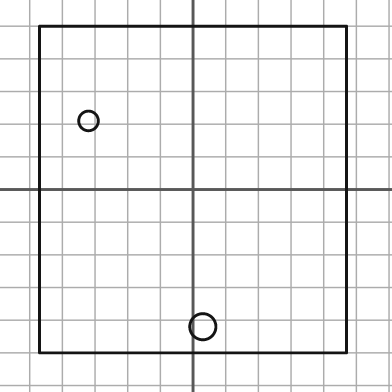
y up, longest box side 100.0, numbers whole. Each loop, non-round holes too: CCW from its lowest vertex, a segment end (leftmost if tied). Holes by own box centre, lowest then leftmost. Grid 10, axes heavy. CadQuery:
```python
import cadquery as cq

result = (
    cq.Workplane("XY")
    .moveTo(-47.0, -50.0)
    .lineTo(47.0, -50.0)
    .lineTo(47.0, 50.0)
    .lineTo(-47.0, 50.0)
    .close()
    .moveTo(3.0, -42.0)
    .circle(4.0)
    .moveTo(-32.0, 21.0)
    .circle(3.0)
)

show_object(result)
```